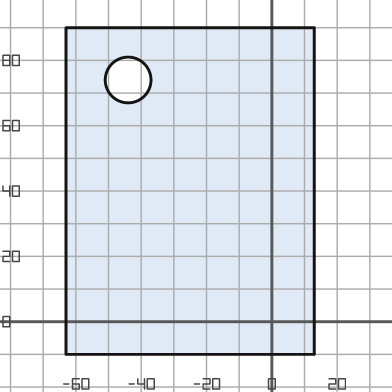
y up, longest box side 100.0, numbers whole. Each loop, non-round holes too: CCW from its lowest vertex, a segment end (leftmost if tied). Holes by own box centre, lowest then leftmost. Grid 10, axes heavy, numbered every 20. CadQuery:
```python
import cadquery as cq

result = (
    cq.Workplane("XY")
    .moveTo(-63.0, -10.0)
    .lineTo(13.0, -10.0)
    .lineTo(13.0, 90.0)
    .lineTo(-63.0, 90.0)
    .close()
    .moveTo(-44.0, 74.0)
    .circle(7.0)
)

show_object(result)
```